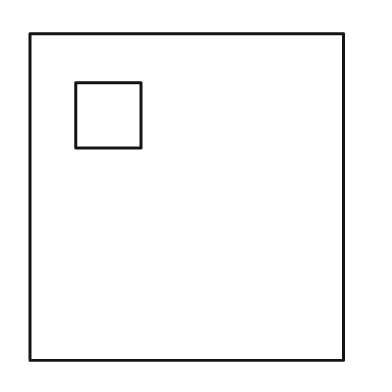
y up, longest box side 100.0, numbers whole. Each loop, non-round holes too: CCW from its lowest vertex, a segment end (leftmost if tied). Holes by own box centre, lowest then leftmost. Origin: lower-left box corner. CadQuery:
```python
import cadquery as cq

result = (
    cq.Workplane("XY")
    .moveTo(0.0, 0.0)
    .lineTo(96.0, 0.0)
    .lineTo(96.0, 100.0)
    .lineTo(0.0, 100.0)
    .close()
    .moveTo(14.0, 65.0)
    .lineTo(34.0, 65.0)
    .lineTo(34.0, 85.0)
    .lineTo(14.0, 85.0)
    .close()
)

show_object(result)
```